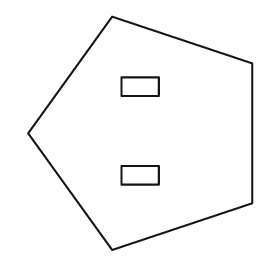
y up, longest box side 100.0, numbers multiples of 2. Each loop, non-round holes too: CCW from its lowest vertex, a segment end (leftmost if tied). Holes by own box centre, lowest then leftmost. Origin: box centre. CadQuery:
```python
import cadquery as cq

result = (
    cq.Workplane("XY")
    .moveTo(-12.0, -50.0)
    .lineTo(48.0, -30.0)
    .lineTo(48.0, 30.0)
    .lineTo(-12.0, 50.0)
    .lineTo(-48.0, 0.0)
    .close()
    .moveTo(-8.0, -22.0)
    .lineTo(8.0, -22.0)
    .lineTo(8.0, -14.0)
    .lineTo(-8.0, -14.0)
    .close()
    .moveTo(-8.0, 16.0)
    .lineTo(8.0, 16.0)
    .lineTo(8.0, 24.0)
    .lineTo(-8.0, 24.0)
    .close()
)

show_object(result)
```